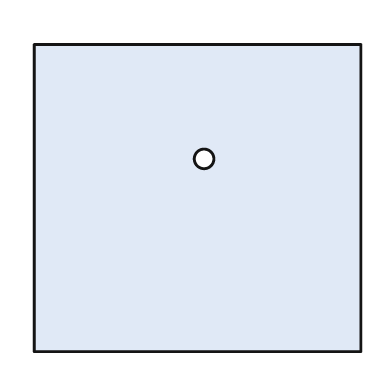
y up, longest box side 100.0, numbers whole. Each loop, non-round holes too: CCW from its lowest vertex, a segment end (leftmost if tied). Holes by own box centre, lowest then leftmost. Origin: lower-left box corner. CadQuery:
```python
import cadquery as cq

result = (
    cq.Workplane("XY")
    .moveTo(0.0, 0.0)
    .lineTo(100.0, 0.0)
    .lineTo(100.0, 94.0)
    .lineTo(0.0, 94.0)
    .close()
    .moveTo(52.0, 59.0)
    .circle(3.0)
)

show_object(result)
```